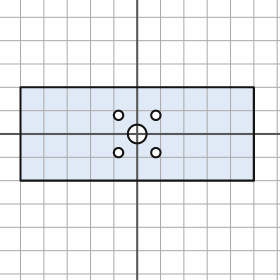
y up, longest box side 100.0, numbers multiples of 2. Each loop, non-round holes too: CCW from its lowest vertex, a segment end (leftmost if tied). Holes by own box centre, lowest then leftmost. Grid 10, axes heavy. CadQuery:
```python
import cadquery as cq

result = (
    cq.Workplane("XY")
    .moveTo(-50.0, -20.0)
    .lineTo(50.0, -20.0)
    .lineTo(50.0, 20.0)
    .lineTo(-50.0, 20.0)
    .close()
    .moveTo(-8.0, -8.0)
    .circle(2.0)
    .moveTo(8.0, -8.0)
    .circle(2.0)
    .moveTo(0.0, 0.0)
    .circle(4.0)
    .moveTo(-8.0, 8.0)
    .circle(2.0)
    .moveTo(8.0, 8.0)
    .circle(2.0)
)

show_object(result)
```